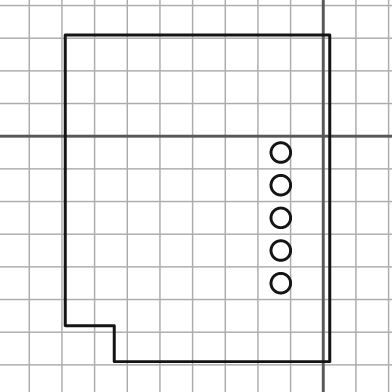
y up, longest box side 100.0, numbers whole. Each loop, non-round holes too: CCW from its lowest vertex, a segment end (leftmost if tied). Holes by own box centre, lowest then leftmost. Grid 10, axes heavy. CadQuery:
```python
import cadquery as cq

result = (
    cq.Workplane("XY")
    .moveTo(-64.0, -69.0)
    .lineTo(2.0, -69.0)
    .lineTo(2.0, 31.0)
    .lineTo(-79.0, 31.0)
    .lineTo(-79.0, -58.0)
    .lineTo(-64.0, -58.0)
    .close()
    .moveTo(-13.0, -45.0)
    .circle(3.0)
    .moveTo(-13.0, -35.0)
    .circle(3.0)
    .moveTo(-13.0, -25.0)
    .circle(3.0)
    .moveTo(-13.0, -15.0)
    .circle(3.0)
    .moveTo(-13.0, -5.0)
    .circle(3.0)
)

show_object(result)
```